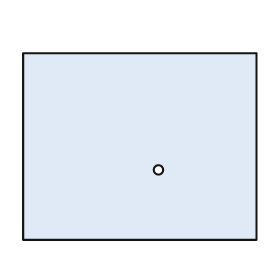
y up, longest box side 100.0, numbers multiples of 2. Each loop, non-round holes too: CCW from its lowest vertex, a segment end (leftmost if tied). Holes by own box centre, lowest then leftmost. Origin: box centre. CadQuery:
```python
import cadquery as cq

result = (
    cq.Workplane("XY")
    .moveTo(-50.0, -40.0)
    .lineTo(50.0, -40.0)
    .lineTo(50.0, 40.0)
    .lineTo(-50.0, 40.0)
    .close()
    .moveTo(8.0, -10.0)
    .circle(2.0)
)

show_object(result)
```